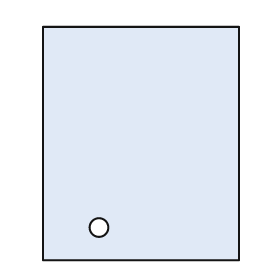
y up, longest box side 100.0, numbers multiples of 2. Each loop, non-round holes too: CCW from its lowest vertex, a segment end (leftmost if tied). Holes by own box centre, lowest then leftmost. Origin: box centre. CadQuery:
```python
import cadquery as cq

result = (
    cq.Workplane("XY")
    .moveTo(-42.0, -50.0)
    .lineTo(42.0, -50.0)
    .lineTo(42.0, 50.0)
    .lineTo(-42.0, 50.0)
    .close()
    .moveTo(-18.0, -36.0)
    .circle(4.0)
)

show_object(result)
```